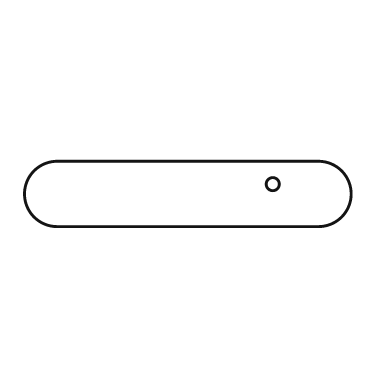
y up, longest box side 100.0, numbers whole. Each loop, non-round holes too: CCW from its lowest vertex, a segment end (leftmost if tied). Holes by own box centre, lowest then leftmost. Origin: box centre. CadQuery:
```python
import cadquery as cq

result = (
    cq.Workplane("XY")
    .moveTo(-40.0, -10.0)
    .lineTo(40.0, -10.0)
    .threePointArc((50.0, 0.0), (40.0, 10.0))
    .lineTo(-40.0, 10.0)
    .threePointArc((-50.0, 0.0), (-40.0, -10.0))
    .close()
    .moveTo(26.0, 3.0)
    .circle(2.0)
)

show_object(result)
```